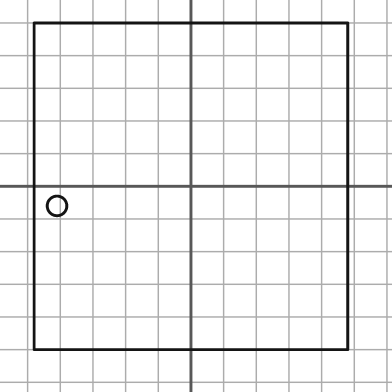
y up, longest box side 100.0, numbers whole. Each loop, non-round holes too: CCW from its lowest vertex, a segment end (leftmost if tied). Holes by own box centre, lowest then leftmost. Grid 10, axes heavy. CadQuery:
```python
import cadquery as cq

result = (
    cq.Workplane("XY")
    .moveTo(-48.0, -50.0)
    .lineTo(48.0, -50.0)
    .lineTo(48.0, 50.0)
    .lineTo(-48.0, 50.0)
    .close()
    .moveTo(-41.0, -6.0)
    .circle(3.0)
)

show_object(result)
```